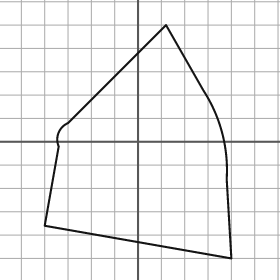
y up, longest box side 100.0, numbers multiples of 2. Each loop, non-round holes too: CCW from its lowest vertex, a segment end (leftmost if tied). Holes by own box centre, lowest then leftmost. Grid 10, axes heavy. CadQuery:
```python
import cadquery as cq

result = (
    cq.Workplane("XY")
    .moveTo(40.0, -50.0)
    .lineTo(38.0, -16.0)
    .threePointArc((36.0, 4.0), (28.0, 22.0))
    .lineTo(12.0, 50.0)
    .lineTo(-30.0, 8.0)
    .threePointArc((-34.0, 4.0), (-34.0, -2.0))
    .lineTo(-40.0, -36.0)
    .close()
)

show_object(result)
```